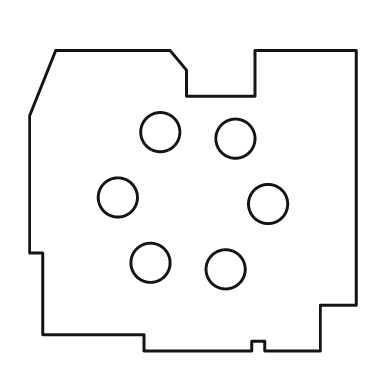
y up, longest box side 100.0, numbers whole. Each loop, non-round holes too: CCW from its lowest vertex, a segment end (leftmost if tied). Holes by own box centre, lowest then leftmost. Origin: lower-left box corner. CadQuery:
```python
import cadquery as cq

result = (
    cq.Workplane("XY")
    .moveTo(35.0, 0.0)
    .lineTo(68.0, 0.0)
    .lineTo(68.0, 3.0)
    .lineTo(72.0, 3.0)
    .lineTo(72.0, 0.0)
    .lineTo(89.0, 0.0)
    .lineTo(89.0, 14.0)
    .lineTo(100.0, 14.0)
    .lineTo(100.0, 92.0)
    .lineTo(69.0, 92.0)
    .lineTo(69.0, 78.0)
    .lineTo(48.0, 78.0)
    .lineTo(48.0, 86.0)
    .lineTo(43.0, 92.0)
    .lineTo(8.0, 92.0)
    .lineTo(0.0, 72.0)
    .lineTo(0.0, 30.0)
    .lineTo(4.0, 30.0)
    .lineTo(4.0, 5.0)
    .lineTo(35.0, 5.0)
    .close()
    .moveTo(60.0, 25.0)
    .circle(6.0)
    .moveTo(37.0, 27.0)
    .circle(6.0)
    .moveTo(73.0, 45.0)
    .circle(6.0)
    .moveTo(27.0, 47.0)
    .circle(6.0)
    .moveTo(63.0, 65.0)
    .circle(6.0)
    .moveTo(40.0, 67.0)
    .circle(6.0)
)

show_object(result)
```